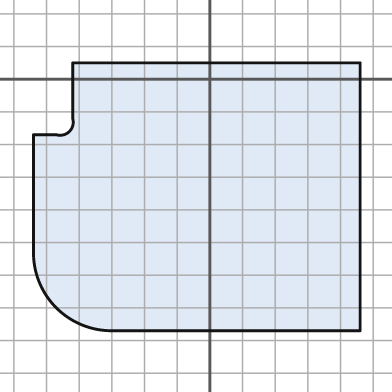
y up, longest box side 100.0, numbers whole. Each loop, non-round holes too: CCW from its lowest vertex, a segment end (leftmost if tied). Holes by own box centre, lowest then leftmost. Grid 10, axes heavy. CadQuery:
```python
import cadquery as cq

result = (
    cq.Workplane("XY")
    .moveTo(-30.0, -77.0)
    .lineTo(46.0, -77.0)
    .lineTo(46.0, 5.0)
    .lineTo(-42.0, 5.0)
    .lineTo(-42.0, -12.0)
    .threePointArc((-43.0, -16.0), (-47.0, -17.0))
    .lineTo(-54.0, -17.0)
    .lineTo(-54.0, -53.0)
    .threePointArc((-47.0, -70.0), (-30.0, -77.0))
    .close()
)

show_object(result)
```